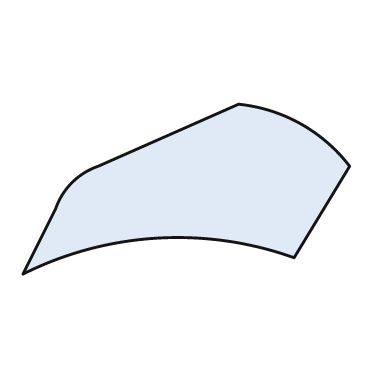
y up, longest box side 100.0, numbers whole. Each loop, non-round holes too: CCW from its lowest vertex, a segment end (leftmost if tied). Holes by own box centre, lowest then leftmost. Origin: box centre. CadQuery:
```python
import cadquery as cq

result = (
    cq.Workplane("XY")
    .moveTo(-50.0, -26.0)
    .threePointArc((-9.0, -15.0), (33.0, -21.0))
    .lineTo(50.0, 7.0)
    .threePointArc((35.0, 20.0), (16.0, 26.0))
    .lineTo(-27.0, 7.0)
    .threePointArc((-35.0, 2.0), (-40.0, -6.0))
    .close()
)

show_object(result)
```